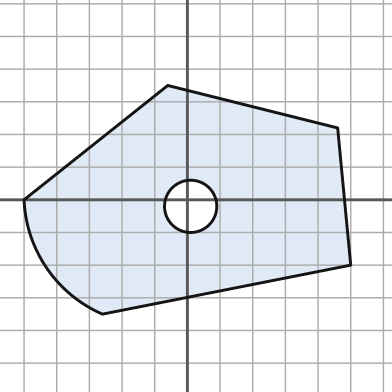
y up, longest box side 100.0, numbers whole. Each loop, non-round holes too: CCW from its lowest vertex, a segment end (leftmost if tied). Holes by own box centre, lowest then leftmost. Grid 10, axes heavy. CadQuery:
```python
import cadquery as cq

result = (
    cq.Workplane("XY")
    .moveTo(-26.0, -35.0)
    .lineTo(50.0, -20.0)
    .lineTo(46.0, 22.0)
    .lineTo(-6.0, 35.0)
    .lineTo(-50.0, 0.0)
    .threePointArc((-43.0, -21.0), (-26.0, -35.0))
    .close()
    .moveTo(1.0, -2.0)
    .circle(8.0)
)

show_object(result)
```